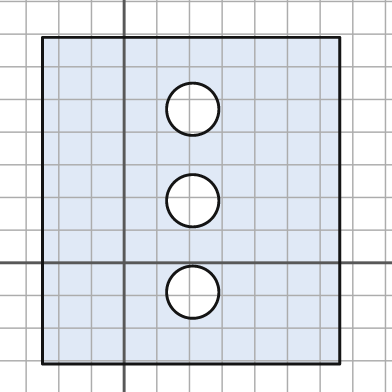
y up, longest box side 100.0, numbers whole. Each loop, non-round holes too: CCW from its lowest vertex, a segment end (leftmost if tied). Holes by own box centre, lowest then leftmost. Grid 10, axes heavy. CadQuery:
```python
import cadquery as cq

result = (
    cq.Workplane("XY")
    .moveTo(-25.0, -31.0)
    .lineTo(66.0, -31.0)
    .lineTo(66.0, 69.0)
    .lineTo(-25.0, 69.0)
    .close()
    .moveTo(21.0, -9.0)
    .circle(8.0)
    .moveTo(21.0, 19.0)
    .circle(8.0)
    .moveTo(21.0, 47.0)
    .circle(8.0)
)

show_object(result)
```